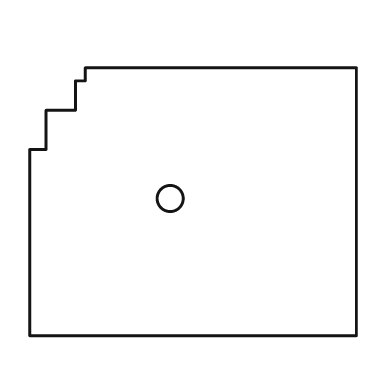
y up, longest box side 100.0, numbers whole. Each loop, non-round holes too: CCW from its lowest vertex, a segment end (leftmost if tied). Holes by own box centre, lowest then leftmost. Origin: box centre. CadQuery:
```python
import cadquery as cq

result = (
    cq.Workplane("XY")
    .moveTo(-50.0, -41.0)
    .lineTo(50.0, -41.0)
    .lineTo(50.0, 41.0)
    .lineTo(-33.0, 41.0)
    .lineTo(-33.0, 37.0)
    .lineTo(-36.0, 37.0)
    .lineTo(-36.0, 28.0)
    .lineTo(-45.0, 28.0)
    .lineTo(-45.0, 16.0)
    .lineTo(-50.0, 16.0)
    .close()
    .moveTo(-7.0, 1.0)
    .circle(4.0)
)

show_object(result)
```